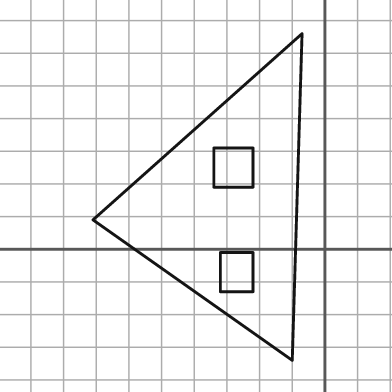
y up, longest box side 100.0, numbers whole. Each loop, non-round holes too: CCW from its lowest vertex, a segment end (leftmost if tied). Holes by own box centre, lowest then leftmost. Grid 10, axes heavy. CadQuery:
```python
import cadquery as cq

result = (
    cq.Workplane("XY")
    .moveTo(-10.0, -34.0)
    .lineTo(-7.0, 66.0)
    .lineTo(-71.0, 9.0)
    .close()
    .moveTo(-32.0, -13.0)
    .lineTo(-22.0, -13.0)
    .lineTo(-22.0, -1.0)
    .lineTo(-32.0, -1.0)
    .close()
    .moveTo(-34.0, 19.0)
    .lineTo(-22.0, 19.0)
    .lineTo(-22.0, 31.0)
    .lineTo(-34.0, 31.0)
    .close()
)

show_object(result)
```